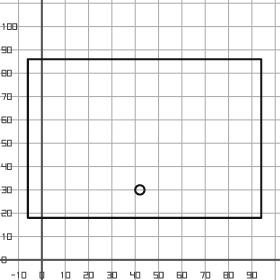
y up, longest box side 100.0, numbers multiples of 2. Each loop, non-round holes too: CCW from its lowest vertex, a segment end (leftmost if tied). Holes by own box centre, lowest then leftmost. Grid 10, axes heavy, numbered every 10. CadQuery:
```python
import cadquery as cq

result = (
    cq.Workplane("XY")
    .moveTo(-6.0, 18.0)
    .lineTo(94.0, 18.0)
    .lineTo(94.0, 86.0)
    .lineTo(-6.0, 86.0)
    .close()
    .moveTo(42.0, 30.0)
    .circle(2.0)
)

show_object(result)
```